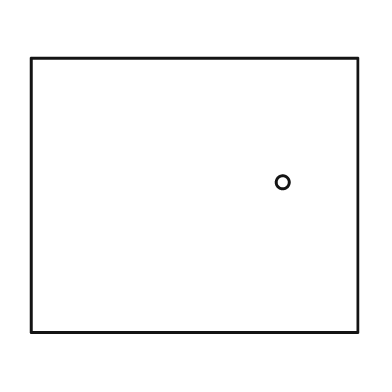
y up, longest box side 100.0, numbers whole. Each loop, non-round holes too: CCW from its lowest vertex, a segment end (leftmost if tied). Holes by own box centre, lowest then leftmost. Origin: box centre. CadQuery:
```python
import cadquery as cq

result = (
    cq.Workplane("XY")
    .moveTo(-50.0, -42.0)
    .lineTo(50.0, -42.0)
    .lineTo(50.0, 42.0)
    .lineTo(-50.0, 42.0)
    .close()
    .moveTo(27.0, 4.0)
    .circle(2.0)
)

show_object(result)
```